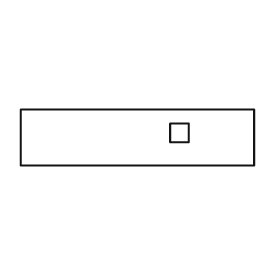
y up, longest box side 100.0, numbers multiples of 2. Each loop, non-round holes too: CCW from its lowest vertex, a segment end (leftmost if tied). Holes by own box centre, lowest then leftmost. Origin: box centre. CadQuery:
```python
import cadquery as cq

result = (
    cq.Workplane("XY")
    .moveTo(-50.0, -12.0)
    .lineTo(50.0, -12.0)
    .lineTo(50.0, 12.0)
    .lineTo(-50.0, 12.0)
    .close()
    .moveTo(14.0, -2.0)
    .lineTo(22.0, -2.0)
    .lineTo(22.0, 6.0)
    .lineTo(14.0, 6.0)
    .close()
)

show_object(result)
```